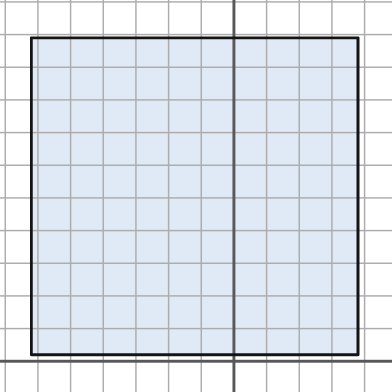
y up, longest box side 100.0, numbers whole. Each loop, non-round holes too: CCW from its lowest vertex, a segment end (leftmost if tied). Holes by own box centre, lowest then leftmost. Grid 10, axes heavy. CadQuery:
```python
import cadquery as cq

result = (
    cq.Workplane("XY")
    .moveTo(-62.0, 2.0)
    .lineTo(38.0, 2.0)
    .lineTo(38.0, 99.0)
    .lineTo(-62.0, 99.0)
    .close()
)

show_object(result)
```